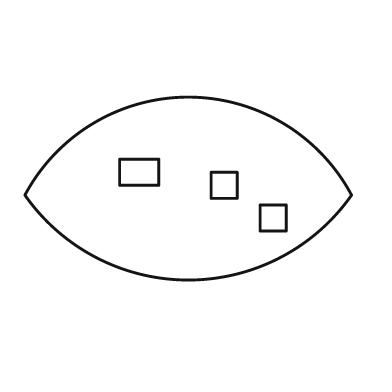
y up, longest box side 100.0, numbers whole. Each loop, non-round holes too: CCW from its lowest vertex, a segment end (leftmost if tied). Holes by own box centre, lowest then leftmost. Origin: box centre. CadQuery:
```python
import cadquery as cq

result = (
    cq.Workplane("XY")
    .moveTo(-50.0, -2.0)
    .threePointArc((0.0, -28.0), (50.0, -2.0))
    .threePointArc((0.0, 28.0), (-50.0, -2.0))
    .close()
    .moveTo(22.0, -13.0)
    .lineTo(30.0, -13.0)
    .lineTo(30.0, -5.0)
    .lineTo(22.0, -5.0)
    .close()
    .moveTo(7.0, -3.0)
    .lineTo(15.0, -3.0)
    .lineTo(15.0, 5.0)
    .lineTo(7.0, 5.0)
    .close()
    .moveTo(-21.0, 1.0)
    .lineTo(-9.0, 1.0)
    .lineTo(-9.0, 9.0)
    .lineTo(-21.0, 9.0)
    .close()
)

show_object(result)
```